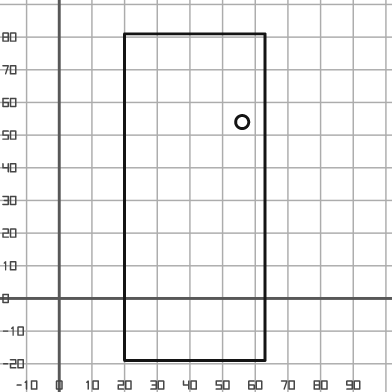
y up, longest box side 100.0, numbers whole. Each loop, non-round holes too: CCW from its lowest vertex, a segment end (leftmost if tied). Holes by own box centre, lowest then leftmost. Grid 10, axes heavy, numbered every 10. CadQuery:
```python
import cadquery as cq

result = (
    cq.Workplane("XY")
    .moveTo(20.0, -19.0)
    .lineTo(63.0, -19.0)
    .lineTo(63.0, 81.0)
    .lineTo(20.0, 81.0)
    .close()
    .moveTo(56.0, 54.0)
    .circle(2.0)
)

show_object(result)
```